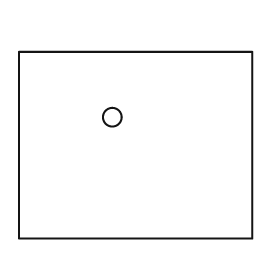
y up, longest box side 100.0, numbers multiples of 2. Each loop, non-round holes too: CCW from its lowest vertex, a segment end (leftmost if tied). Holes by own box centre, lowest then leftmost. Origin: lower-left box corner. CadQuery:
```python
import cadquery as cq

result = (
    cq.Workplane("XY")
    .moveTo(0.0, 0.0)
    .lineTo(100.0, 0.0)
    .lineTo(100.0, 80.0)
    .lineTo(0.0, 80.0)
    .close()
    .moveTo(40.0, 52.0)
    .circle(4.0)
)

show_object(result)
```